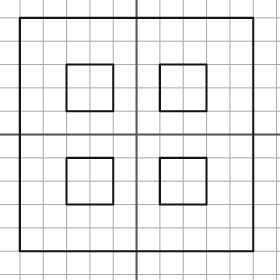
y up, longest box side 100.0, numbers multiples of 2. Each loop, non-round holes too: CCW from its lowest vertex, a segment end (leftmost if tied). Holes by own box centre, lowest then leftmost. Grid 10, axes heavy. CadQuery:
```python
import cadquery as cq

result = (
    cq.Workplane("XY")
    .moveTo(-50.0, -50.0)
    .lineTo(50.0, -50.0)
    .lineTo(50.0, 50.0)
    .lineTo(-50.0, 50.0)
    .close()
    .moveTo(-30.0, -30.0)
    .lineTo(-10.0, -30.0)
    .lineTo(-10.0, -10.0)
    .lineTo(-30.0, -10.0)
    .close()
    .moveTo(10.0, -30.0)
    .lineTo(30.0, -30.0)
    .lineTo(30.0, -10.0)
    .lineTo(10.0, -10.0)
    .close()
    .moveTo(-30.0, 10.0)
    .lineTo(-10.0, 10.0)
    .lineTo(-10.0, 30.0)
    .lineTo(-30.0, 30.0)
    .close()
    .moveTo(10.0, 10.0)
    .lineTo(30.0, 10.0)
    .lineTo(30.0, 30.0)
    .lineTo(10.0, 30.0)
    .close()
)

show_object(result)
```